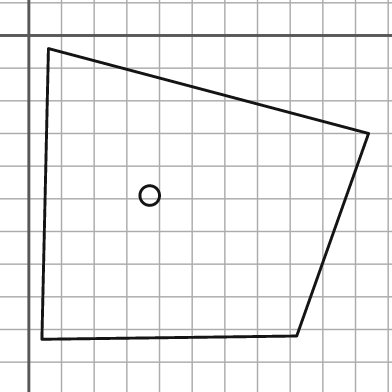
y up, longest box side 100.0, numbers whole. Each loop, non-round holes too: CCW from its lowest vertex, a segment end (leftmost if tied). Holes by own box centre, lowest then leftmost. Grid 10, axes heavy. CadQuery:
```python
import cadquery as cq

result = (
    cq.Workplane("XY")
    .moveTo(4.0, -93.0)
    .lineTo(82.0, -92.0)
    .lineTo(104.0, -30.0)
    .lineTo(6.0, -4.0)
    .close()
    .moveTo(37.0, -49.0)
    .circle(3.0)
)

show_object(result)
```